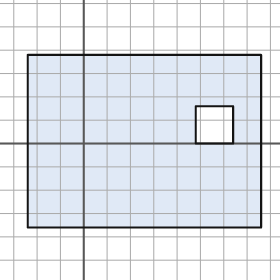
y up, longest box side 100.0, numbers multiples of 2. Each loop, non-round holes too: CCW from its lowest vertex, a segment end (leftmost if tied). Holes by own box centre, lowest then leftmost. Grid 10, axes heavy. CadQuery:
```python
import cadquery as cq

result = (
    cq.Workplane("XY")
    .moveTo(-24.0, -36.0)
    .lineTo(76.0, -36.0)
    .lineTo(76.0, 38.0)
    .lineTo(-24.0, 38.0)
    .close()
    .moveTo(48.0, 0.0)
    .lineTo(64.0, 0.0)
    .lineTo(64.0, 16.0)
    .lineTo(48.0, 16.0)
    .close()
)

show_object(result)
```